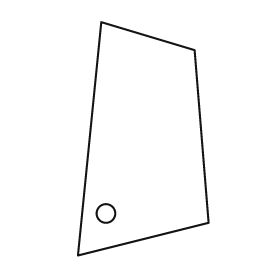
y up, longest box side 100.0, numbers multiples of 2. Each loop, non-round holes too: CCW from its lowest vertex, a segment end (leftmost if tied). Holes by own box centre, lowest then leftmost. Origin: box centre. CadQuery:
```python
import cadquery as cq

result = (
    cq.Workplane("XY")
    .moveTo(-28.0, -50.0)
    .lineTo(28.0, -36.0)
    .lineTo(22.0, 38.0)
    .lineTo(-18.0, 50.0)
    .close()
    .moveTo(-16.0, -32.0)
    .circle(4.0)
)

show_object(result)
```